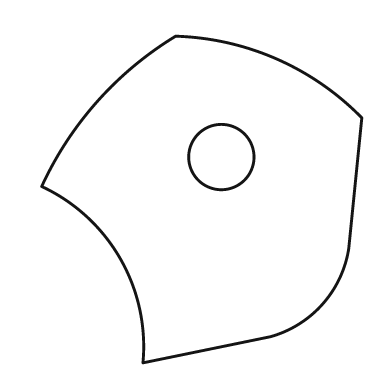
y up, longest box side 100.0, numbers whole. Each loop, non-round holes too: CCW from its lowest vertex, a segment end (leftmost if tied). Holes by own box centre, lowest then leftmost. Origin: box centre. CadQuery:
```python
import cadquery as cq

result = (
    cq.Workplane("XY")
    .moveTo(-18.0, -50.0)
    .lineTo(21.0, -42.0)
    .threePointArc((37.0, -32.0), (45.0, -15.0))
    .lineTo(49.0, 25.0)
    .threePointArc((23.0, 43.0), (-8.0, 50.0))
    .threePointArc((-32.0, 30.0), (-49.0, 4.0))
    .threePointArc((-25.0, -18.0), (-18.0, -50.0))
    .close()
    .moveTo(6.0, 13.0)
    .circle(10.0)
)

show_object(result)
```